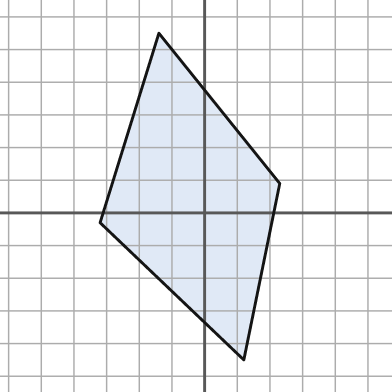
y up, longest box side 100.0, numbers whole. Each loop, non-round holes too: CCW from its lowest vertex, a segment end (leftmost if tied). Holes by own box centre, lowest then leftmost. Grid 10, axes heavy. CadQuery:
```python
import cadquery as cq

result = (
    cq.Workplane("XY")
    .moveTo(12.0, -45.0)
    .lineTo(23.0, 9.0)
    .lineTo(-14.0, 55.0)
    .lineTo(-32.0, -3.0)
    .close()
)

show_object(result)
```